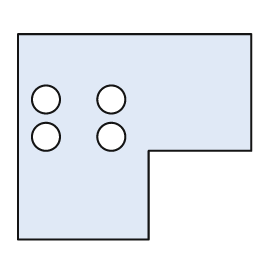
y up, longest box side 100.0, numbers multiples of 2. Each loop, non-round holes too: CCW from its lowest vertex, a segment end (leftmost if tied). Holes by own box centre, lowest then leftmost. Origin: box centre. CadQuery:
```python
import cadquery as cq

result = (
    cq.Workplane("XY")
    .moveTo(-50.0, -44.0)
    .lineTo(6.0, -44.0)
    .lineTo(6.0, -6.0)
    .lineTo(50.0, -6.0)
    .lineTo(50.0, 44.0)
    .lineTo(-50.0, 44.0)
    .close()
    .moveTo(-38.0, 0.0)
    .circle(6.0)
    .moveTo(-10.0, 0.0)
    .circle(6.0)
    .moveTo(-38.0, 16.0)
    .circle(6.0)
    .moveTo(-10.0, 16.0)
    .circle(6.0)
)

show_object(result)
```